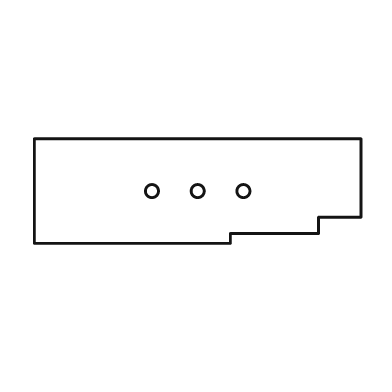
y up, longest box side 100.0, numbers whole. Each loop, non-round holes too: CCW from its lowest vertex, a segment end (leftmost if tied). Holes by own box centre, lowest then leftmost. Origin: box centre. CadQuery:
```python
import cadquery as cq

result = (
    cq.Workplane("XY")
    .moveTo(-50.0, -16.0)
    .lineTo(10.0, -16.0)
    .lineTo(10.0, -13.0)
    .lineTo(37.0, -13.0)
    .lineTo(37.0, -8.0)
    .lineTo(50.0, -8.0)
    .lineTo(50.0, 16.0)
    .lineTo(-50.0, 16.0)
    .close()
    .moveTo(-14.0, 0.0)
    .circle(2.0)
    .moveTo(0.0, 0.0)
    .circle(2.0)
    .moveTo(14.0, 0.0)
    .circle(2.0)
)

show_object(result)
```